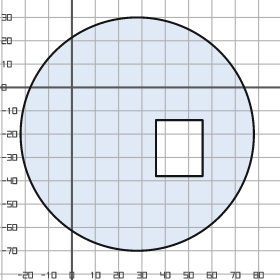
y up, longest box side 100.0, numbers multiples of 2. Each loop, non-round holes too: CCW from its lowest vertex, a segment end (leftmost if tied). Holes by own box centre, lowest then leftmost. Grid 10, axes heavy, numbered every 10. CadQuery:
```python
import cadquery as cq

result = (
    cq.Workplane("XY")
    .moveTo(28.0, -20.0)
    .circle(50.0)
    .moveTo(36.0, -38.0)
    .lineTo(56.0, -38.0)
    .lineTo(56.0, -14.0)
    .lineTo(36.0, -14.0)
    .close()
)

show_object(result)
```